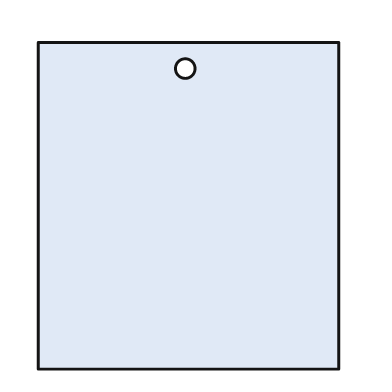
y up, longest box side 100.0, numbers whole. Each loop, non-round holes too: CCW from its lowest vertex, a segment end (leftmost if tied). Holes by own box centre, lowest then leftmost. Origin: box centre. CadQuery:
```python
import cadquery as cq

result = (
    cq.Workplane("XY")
    .moveTo(-46.0, -50.0)
    .lineTo(46.0, -50.0)
    .lineTo(46.0, 50.0)
    .lineTo(-46.0, 50.0)
    .close()
    .moveTo(-1.0, 42.0)
    .circle(3.0)
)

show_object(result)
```